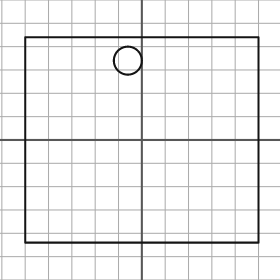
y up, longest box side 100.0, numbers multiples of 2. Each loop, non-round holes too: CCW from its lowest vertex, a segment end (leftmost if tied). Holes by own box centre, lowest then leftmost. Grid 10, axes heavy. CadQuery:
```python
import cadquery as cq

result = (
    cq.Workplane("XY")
    .moveTo(-50.0, -44.0)
    .lineTo(50.0, -44.0)
    .lineTo(50.0, 44.0)
    .lineTo(-50.0, 44.0)
    .close()
    .moveTo(-6.0, 34.0)
    .circle(6.0)
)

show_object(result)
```